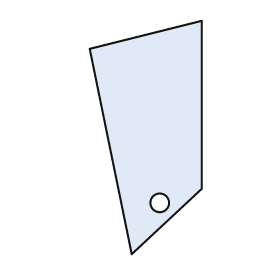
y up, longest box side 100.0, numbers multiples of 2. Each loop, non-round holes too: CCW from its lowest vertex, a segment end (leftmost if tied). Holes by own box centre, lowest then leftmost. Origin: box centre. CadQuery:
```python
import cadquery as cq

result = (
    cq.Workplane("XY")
    .moveTo(-6.0, -50.0)
    .lineTo(24.0, -22.0)
    .lineTo(24.0, 50.0)
    .lineTo(-24.0, 38.0)
    .close()
    .moveTo(6.0, -28.0)
    .circle(4.0)
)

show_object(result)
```